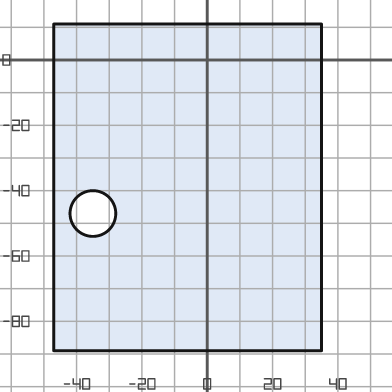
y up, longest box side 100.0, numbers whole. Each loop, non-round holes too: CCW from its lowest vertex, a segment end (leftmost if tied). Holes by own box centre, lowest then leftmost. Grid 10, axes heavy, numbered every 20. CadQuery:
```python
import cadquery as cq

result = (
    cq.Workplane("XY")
    .moveTo(-47.0, -89.0)
    .lineTo(35.0, -89.0)
    .lineTo(35.0, 11.0)
    .lineTo(-47.0, 11.0)
    .close()
    .moveTo(-35.0, -47.0)
    .circle(7.0)
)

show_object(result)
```